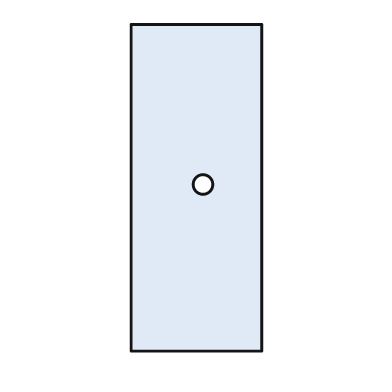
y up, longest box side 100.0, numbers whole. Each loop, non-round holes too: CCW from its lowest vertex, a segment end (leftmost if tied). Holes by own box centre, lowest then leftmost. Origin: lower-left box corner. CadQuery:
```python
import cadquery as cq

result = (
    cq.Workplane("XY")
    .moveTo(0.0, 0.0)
    .lineTo(40.0, 0.0)
    .lineTo(40.0, 100.0)
    .lineTo(0.0, 100.0)
    .close()
    .moveTo(22.0, 51.0)
    .circle(3.0)
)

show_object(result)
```